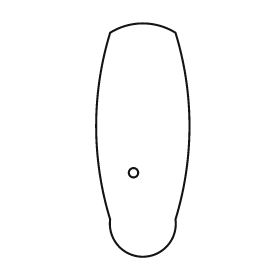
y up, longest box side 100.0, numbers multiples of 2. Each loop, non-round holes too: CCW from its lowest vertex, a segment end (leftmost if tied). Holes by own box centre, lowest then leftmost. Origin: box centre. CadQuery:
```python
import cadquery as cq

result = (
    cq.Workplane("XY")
    .moveTo(-14.0, -34.0)
    .threePointArc((0.0, -50.0), (14.0, -34.0))
    .threePointArc((20.0, 6.0), (14.0, 46.0))
    .threePointArc((0.0, 50.0), (-14.0, 46.0))
    .threePointArc((-20.0, 6.0), (-14.0, -34.0))
    .close()
    .moveTo(-4.0, -14.0)
    .circle(2.0)
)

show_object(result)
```